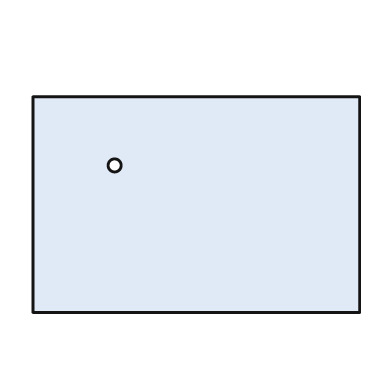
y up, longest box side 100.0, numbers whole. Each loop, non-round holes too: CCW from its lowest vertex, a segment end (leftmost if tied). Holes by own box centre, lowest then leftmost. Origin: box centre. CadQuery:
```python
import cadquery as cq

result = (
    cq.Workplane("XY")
    .moveTo(-50.0, -33.0)
    .lineTo(50.0, -33.0)
    .lineTo(50.0, 33.0)
    .lineTo(-50.0, 33.0)
    .close()
    .moveTo(-25.0, 12.0)
    .circle(2.0)
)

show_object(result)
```